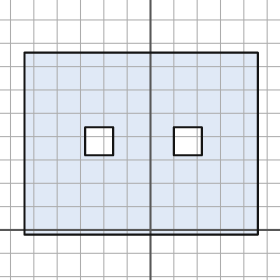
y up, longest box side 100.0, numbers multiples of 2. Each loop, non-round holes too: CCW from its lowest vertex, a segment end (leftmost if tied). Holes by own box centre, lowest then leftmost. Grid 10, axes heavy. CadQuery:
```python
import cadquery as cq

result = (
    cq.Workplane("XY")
    .moveTo(-54.0, -2.0)
    .lineTo(46.0, -2.0)
    .lineTo(46.0, 76.0)
    .lineTo(-54.0, 76.0)
    .close()
    .moveTo(-28.0, 32.0)
    .lineTo(-16.0, 32.0)
    .lineTo(-16.0, 44.0)
    .lineTo(-28.0, 44.0)
    .close()
    .moveTo(10.0, 32.0)
    .lineTo(22.0, 32.0)
    .lineTo(22.0, 44.0)
    .lineTo(10.0, 44.0)
    .close()
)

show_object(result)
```